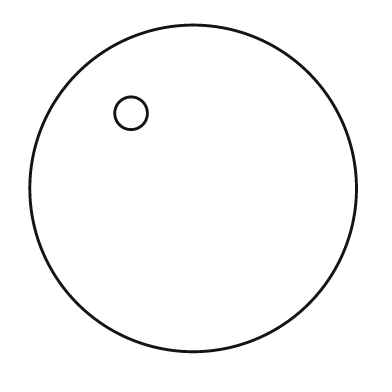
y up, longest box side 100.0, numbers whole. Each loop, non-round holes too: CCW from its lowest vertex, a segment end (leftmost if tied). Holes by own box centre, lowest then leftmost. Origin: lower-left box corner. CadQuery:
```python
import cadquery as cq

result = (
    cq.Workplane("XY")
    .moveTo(50.0, 50.0)
    .circle(50.0)
    .moveTo(31.0, 73.0)
    .circle(5.0)
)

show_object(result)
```